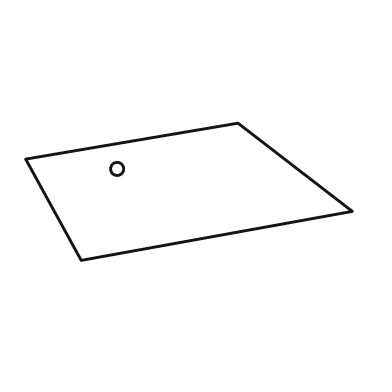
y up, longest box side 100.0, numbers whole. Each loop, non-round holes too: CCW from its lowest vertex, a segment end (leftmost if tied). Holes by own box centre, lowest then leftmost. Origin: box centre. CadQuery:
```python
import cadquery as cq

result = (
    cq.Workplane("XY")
    .moveTo(-33.0, -21.0)
    .lineTo(50.0, -6.0)
    .lineTo(15.0, 21.0)
    .lineTo(-50.0, 10.0)
    .close()
    .moveTo(-22.0, 7.0)
    .circle(2.0)
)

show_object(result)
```